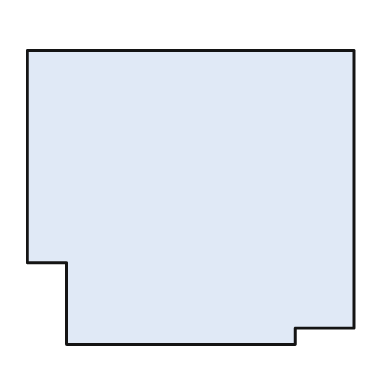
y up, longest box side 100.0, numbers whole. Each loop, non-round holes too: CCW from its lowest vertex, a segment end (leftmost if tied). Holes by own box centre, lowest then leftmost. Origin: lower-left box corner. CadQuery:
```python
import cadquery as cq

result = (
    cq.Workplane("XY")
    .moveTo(12.0, 0.0)
    .lineTo(82.0, 0.0)
    .lineTo(82.0, 5.0)
    .lineTo(100.0, 5.0)
    .lineTo(100.0, 90.0)
    .lineTo(0.0, 90.0)
    .lineTo(0.0, 25.0)
    .lineTo(12.0, 25.0)
    .close()
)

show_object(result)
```